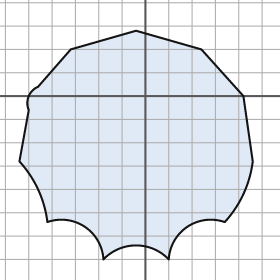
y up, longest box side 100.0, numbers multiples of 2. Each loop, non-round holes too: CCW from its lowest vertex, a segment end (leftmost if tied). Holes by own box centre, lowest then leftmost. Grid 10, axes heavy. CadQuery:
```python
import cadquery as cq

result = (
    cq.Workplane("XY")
    .moveTo(-18.0, -70.0)
    .threePointArc((-4.0, -64.0), (10.0, -70.0))
    .threePointArc((18.0, -56.0), (34.0, -54.0))
    .threePointArc((42.0, -42.0), (46.0, -28.0))
    .lineTo(42.0, 0.0)
    .lineTo(24.0, 20.0)
    .lineTo(-4.0, 28.0)
    .lineTo(-32.0, 20.0)
    .lineTo(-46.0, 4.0)
    .threePointArc((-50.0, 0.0), (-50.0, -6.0))
    .lineTo(-54.0, -28.0)
    .threePointArc((-46.0, -40.0), (-42.0, -54.0))
    .threePointArc((-26.0, -56.0), (-18.0, -70.0))
    .close()
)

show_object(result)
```